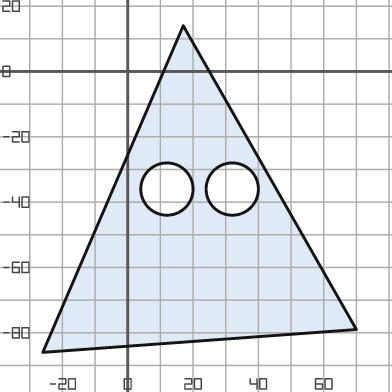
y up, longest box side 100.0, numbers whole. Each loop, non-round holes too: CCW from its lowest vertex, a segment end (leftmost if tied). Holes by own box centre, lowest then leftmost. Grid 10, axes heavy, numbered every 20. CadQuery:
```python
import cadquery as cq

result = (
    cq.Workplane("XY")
    .moveTo(-26.0, -86.0)
    .lineTo(70.0, -79.0)
    .lineTo(17.0, 14.0)
    .close()
    .moveTo(12.0, -36.0)
    .circle(8.0)
    .moveTo(32.0, -36.0)
    .circle(8.0)
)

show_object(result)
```